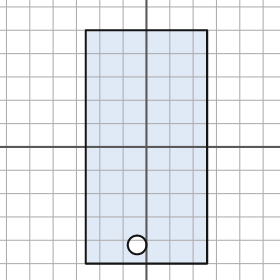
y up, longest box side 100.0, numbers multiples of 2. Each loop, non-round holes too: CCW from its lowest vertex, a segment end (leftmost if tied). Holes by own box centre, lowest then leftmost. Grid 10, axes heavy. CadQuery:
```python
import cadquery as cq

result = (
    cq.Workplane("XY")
    .moveTo(-26.0, -50.0)
    .lineTo(26.0, -50.0)
    .lineTo(26.0, 50.0)
    .lineTo(-26.0, 50.0)
    .close()
    .moveTo(-4.0, -42.0)
    .circle(4.0)
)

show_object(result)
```